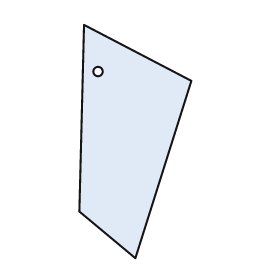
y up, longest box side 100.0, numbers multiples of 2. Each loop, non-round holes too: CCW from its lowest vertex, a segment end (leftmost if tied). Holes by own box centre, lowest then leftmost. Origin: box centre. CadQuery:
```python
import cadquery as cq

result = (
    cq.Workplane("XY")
    .moveTo(0.0, -50.0)
    .lineTo(24.0, 26.0)
    .lineTo(-22.0, 50.0)
    .lineTo(-24.0, -30.0)
    .close()
    .moveTo(-16.0, 30.0)
    .circle(2.0)
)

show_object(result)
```